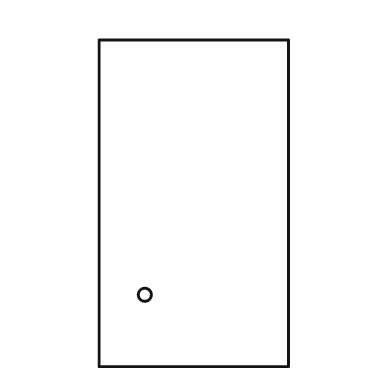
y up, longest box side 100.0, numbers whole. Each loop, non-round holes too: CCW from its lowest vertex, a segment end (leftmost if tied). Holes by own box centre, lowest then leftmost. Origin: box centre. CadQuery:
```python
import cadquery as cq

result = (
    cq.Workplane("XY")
    .moveTo(-29.0, -50.0)
    .lineTo(29.0, -50.0)
    .lineTo(29.0, 50.0)
    .lineTo(-29.0, 50.0)
    .close()
    .moveTo(-15.0, -28.0)
    .circle(2.0)
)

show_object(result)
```